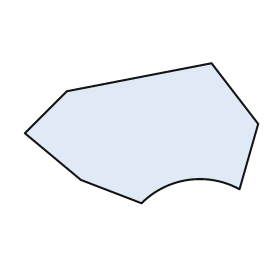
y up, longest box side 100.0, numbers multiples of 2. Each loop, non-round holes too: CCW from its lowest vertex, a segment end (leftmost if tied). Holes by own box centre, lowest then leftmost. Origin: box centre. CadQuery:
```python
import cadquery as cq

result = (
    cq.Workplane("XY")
    .moveTo(0.0, -30.0)
    .threePointArc((20.0, -20.0), (42.0, -24.0))
    .lineTo(50.0, 4.0)
    .lineTo(30.0, 30.0)
    .lineTo(-32.0, 18.0)
    .lineTo(-50.0, 0.0)
    .lineTo(-26.0, -20.0)
    .close()
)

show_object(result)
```